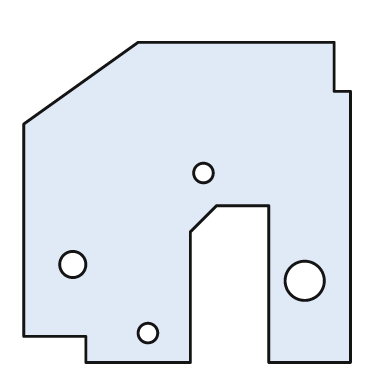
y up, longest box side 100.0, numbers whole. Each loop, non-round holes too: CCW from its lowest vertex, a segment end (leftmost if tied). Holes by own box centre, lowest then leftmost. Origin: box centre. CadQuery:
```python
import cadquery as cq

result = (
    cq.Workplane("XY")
    .moveTo(-31.0, -49.0)
    .lineTo(1.0, -49.0)
    .lineTo(1.0, -9.0)
    .lineTo(9.0, -1.0)
    .lineTo(25.0, -1.0)
    .lineTo(25.0, -49.0)
    .lineTo(50.0, -49.0)
    .lineTo(50.0, 34.0)
    .lineTo(45.0, 34.0)
    .lineTo(45.0, 49.0)
    .lineTo(-15.0, 49.0)
    .lineTo(-50.0, 24.0)
    .lineTo(-50.0, -41.0)
    .lineTo(-31.0, -41.0)
    .close()
    .moveTo(-12.0, -40.0)
    .circle(3.0)
    .moveTo(36.0, -24.0)
    .circle(6.0)
    .moveTo(-35.0, -19.0)
    .circle(4.0)
    .moveTo(5.0, 9.0)
    .circle(3.0)
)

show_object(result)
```